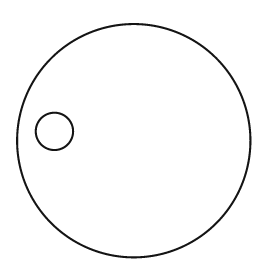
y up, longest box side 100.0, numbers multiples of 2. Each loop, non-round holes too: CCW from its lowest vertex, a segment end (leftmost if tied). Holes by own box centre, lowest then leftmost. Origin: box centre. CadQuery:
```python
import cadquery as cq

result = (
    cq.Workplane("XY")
    .moveTo(0.0, 0.0)
    .circle(50.0)
    .moveTo(-34.0, 4.0)
    .circle(8.0)
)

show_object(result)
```